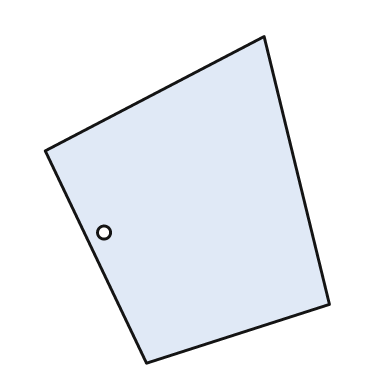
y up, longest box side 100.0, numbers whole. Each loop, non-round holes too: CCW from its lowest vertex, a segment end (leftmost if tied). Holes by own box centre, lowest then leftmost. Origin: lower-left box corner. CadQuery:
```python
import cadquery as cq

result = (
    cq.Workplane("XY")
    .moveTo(31.0, 0.0)
    .lineTo(87.0, 18.0)
    .lineTo(67.0, 100.0)
    .lineTo(0.0, 65.0)
    .close()
    .moveTo(18.0, 40.0)
    .circle(2.0)
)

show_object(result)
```